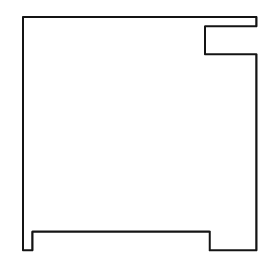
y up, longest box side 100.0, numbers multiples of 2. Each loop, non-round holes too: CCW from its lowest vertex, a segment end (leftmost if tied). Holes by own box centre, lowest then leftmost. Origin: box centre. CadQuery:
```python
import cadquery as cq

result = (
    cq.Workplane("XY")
    .moveTo(-50.0, -50.0)
    .lineTo(-46.0, -50.0)
    .lineTo(-46.0, -42.0)
    .lineTo(30.0, -42.0)
    .lineTo(30.0, -50.0)
    .lineTo(50.0, -50.0)
    .lineTo(50.0, 34.0)
    .lineTo(28.0, 34.0)
    .lineTo(28.0, 46.0)
    .lineTo(50.0, 46.0)
    .lineTo(50.0, 50.0)
    .lineTo(-50.0, 50.0)
    .close()
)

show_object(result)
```